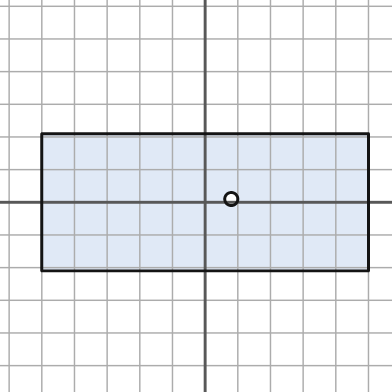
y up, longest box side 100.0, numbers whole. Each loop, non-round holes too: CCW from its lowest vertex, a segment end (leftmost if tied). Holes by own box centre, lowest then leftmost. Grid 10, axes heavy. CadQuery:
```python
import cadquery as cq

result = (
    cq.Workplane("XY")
    .moveTo(-50.0, -21.0)
    .lineTo(50.0, -21.0)
    .lineTo(50.0, 21.0)
    .lineTo(-50.0, 21.0)
    .close()
    .moveTo(8.0, 1.0)
    .circle(2.0)
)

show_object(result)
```